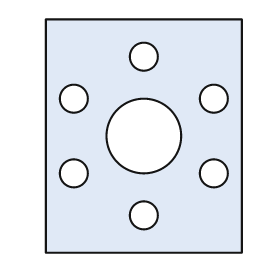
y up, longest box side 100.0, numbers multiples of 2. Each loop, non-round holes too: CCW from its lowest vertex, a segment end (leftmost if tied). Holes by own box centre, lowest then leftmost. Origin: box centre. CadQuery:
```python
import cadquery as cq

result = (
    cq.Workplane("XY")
    .moveTo(-42.0, -50.0)
    .lineTo(42.0, -50.0)
    .lineTo(42.0, 50.0)
    .lineTo(-42.0, 50.0)
    .close()
    .moveTo(0.0, -34.0)
    .circle(6.0)
    .moveTo(-30.0, -16.0)
    .circle(6.0)
    .moveTo(30.0, -16.0)
    .circle(6.0)
    .moveTo(0.0, 0.0)
    .circle(16.0)
    .moveTo(-30.0, 16.0)
    .circle(6.0)
    .moveTo(30.0, 16.0)
    .circle(6.0)
    .moveTo(0.0, 34.0)
    .circle(6.0)
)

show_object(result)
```